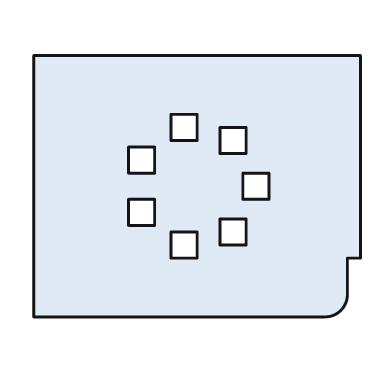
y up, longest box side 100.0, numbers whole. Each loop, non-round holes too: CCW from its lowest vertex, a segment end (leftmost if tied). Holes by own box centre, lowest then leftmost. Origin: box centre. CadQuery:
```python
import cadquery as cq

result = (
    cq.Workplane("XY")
    .moveTo(-50.0, -40.0)
    .lineTo(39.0, -40.0)
    .threePointArc((44.0, -38.0), (46.0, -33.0))
    .lineTo(46.0, -22.0)
    .lineTo(50.0, -22.0)
    .lineTo(50.0, 40.0)
    .lineTo(-50.0, 40.0)
    .close()
    .moveTo(-8.0, -22.0)
    .lineTo(0.0, -22.0)
    .lineTo(0.0, -14.0)
    .lineTo(-8.0, -14.0)
    .close()
    .moveTo(7.0, -18.0)
    .lineTo(15.0, -18.0)
    .lineTo(15.0, -10.0)
    .lineTo(7.0, -10.0)
    .close()
    .moveTo(-21.0, -12.0)
    .lineTo(-13.0, -12.0)
    .lineTo(-13.0, -4.0)
    .lineTo(-21.0, -4.0)
    .close()
    .moveTo(14.0, -4.0)
    .lineTo(22.0, -4.0)
    .lineTo(22.0, 4.0)
    .lineTo(14.0, 4.0)
    .close()
    .moveTo(-21.0, 4.0)
    .lineTo(-13.0, 4.0)
    .lineTo(-13.0, 12.0)
    .lineTo(-21.0, 12.0)
    .close()
    .moveTo(7.0, 10.0)
    .lineTo(15.0, 10.0)
    .lineTo(15.0, 18.0)
    .lineTo(7.0, 18.0)
    .close()
    .moveTo(-8.0, 14.0)
    .lineTo(0.0, 14.0)
    .lineTo(0.0, 22.0)
    .lineTo(-8.0, 22.0)
    .close()
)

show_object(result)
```